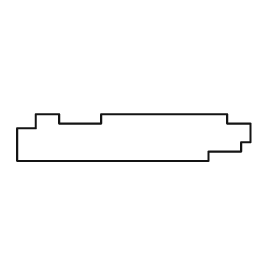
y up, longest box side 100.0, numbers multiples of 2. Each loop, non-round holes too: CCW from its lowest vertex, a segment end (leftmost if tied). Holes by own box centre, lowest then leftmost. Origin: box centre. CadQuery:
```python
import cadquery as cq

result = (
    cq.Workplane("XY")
    .moveTo(-50.0, -10.0)
    .lineTo(32.0, -10.0)
    .lineTo(32.0, -6.0)
    .lineTo(46.0, -6.0)
    .lineTo(46.0, -2.0)
    .lineTo(50.0, -2.0)
    .lineTo(50.0, 6.0)
    .lineTo(40.0, 6.0)
    .lineTo(40.0, 10.0)
    .lineTo(-14.0, 10.0)
    .lineTo(-14.0, 6.0)
    .lineTo(-32.0, 6.0)
    .lineTo(-32.0, 10.0)
    .lineTo(-42.0, 10.0)
    .lineTo(-42.0, 4.0)
    .lineTo(-50.0, 4.0)
    .close()
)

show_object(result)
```